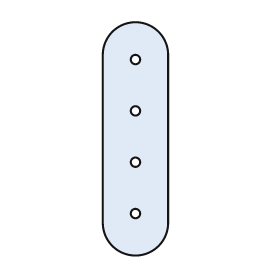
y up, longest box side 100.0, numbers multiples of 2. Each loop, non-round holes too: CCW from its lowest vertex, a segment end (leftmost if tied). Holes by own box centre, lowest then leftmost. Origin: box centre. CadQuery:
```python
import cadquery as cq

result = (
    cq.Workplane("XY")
    .moveTo(-14.0, -36.0)
    .threePointArc((0.0, -50.0), (14.0, -36.0))
    .lineTo(14.0, 36.0)
    .threePointArc((0.0, 50.0), (-14.0, 36.0))
    .close()
    .moveTo(0.0, -32.0)
    .circle(2.0)
    .moveTo(0.0, -10.0)
    .circle(2.0)
    .moveTo(0.0, 12.0)
    .circle(2.0)
    .moveTo(0.0, 34.0)
    .circle(2.0)
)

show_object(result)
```